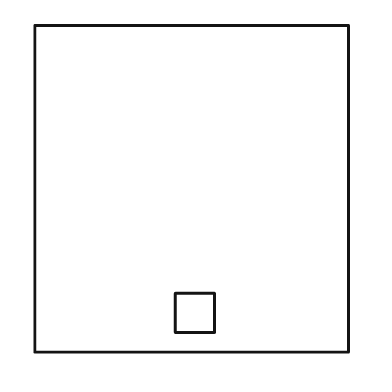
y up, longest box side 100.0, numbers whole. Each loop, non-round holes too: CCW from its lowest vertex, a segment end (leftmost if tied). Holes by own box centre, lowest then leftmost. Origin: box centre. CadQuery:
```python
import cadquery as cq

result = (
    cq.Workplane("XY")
    .moveTo(-48.0, -50.0)
    .lineTo(48.0, -50.0)
    .lineTo(48.0, 50.0)
    .lineTo(-48.0, 50.0)
    .close()
    .moveTo(-5.0, -44.0)
    .lineTo(7.0, -44.0)
    .lineTo(7.0, -32.0)
    .lineTo(-5.0, -32.0)
    .close()
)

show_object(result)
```